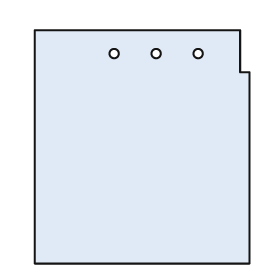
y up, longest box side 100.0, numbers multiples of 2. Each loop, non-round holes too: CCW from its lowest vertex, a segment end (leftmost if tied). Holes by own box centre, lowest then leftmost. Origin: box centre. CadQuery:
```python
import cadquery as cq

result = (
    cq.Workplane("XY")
    .moveTo(-46.0, -50.0)
    .lineTo(46.0, -50.0)
    .lineTo(46.0, 32.0)
    .lineTo(42.0, 32.0)
    .lineTo(42.0, 50.0)
    .lineTo(-46.0, 50.0)
    .close()
    .moveTo(-12.0, 40.0)
    .circle(2.0)
    .moveTo(6.0, 40.0)
    .circle(2.0)
    .moveTo(24.0, 40.0)
    .circle(2.0)
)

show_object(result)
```